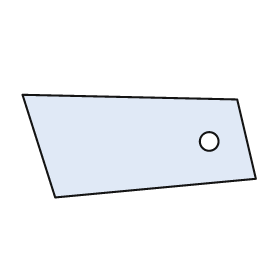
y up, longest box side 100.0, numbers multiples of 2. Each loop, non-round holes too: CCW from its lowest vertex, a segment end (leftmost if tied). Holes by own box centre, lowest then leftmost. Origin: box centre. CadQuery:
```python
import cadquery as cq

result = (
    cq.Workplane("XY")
    .moveTo(-36.0, -22.0)
    .lineTo(50.0, -14.0)
    .lineTo(42.0, 20.0)
    .lineTo(-50.0, 22.0)
    .close()
    .moveTo(30.0, 2.0)
    .circle(4.0)
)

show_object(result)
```